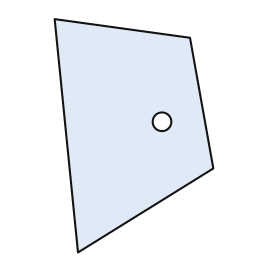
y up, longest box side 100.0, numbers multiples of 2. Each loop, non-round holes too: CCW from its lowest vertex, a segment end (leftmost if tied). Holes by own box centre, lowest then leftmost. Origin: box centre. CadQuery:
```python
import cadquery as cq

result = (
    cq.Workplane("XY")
    .moveTo(-24.0, -50.0)
    .lineTo(34.0, -14.0)
    .lineTo(24.0, 42.0)
    .lineTo(-34.0, 50.0)
    .close()
    .moveTo(12.0, 6.0)
    .circle(4.0)
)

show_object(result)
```